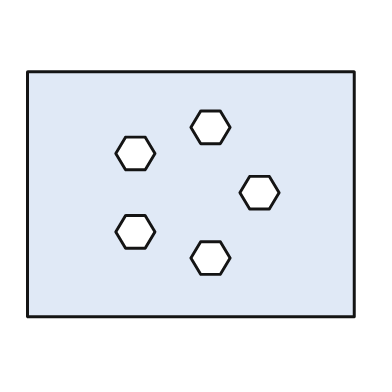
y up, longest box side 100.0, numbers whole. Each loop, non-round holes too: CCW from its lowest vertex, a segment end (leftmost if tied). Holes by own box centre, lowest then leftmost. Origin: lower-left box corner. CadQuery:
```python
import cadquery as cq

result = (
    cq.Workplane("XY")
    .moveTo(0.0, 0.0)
    .lineTo(100.0, 0.0)
    .lineTo(100.0, 75.0)
    .lineTo(0.0, 75.0)
    .close()
    .moveTo(53.0, 13.0)
    .lineTo(59.0, 13.0)
    .lineTo(62.0, 18.0)
    .lineTo(59.0, 23.0)
    .lineTo(53.0, 23.0)
    .lineTo(50.0, 18.0)
    .close()
    .moveTo(30.0, 21.0)
    .lineTo(36.0, 21.0)
    .lineTo(39.0, 26.0)
    .lineTo(36.0, 31.0)
    .lineTo(30.0, 31.0)
    .lineTo(27.0, 26.0)
    .close()
    .moveTo(68.0, 33.0)
    .lineTo(74.0, 33.0)
    .lineTo(77.0, 38.0)
    .lineTo(74.0, 43.0)
    .lineTo(68.0, 43.0)
    .lineTo(65.0, 38.0)
    .close()
    .moveTo(30.0, 45.0)
    .lineTo(36.0, 45.0)
    .lineTo(39.0, 50.0)
    .lineTo(36.0, 55.0)
    .lineTo(30.0, 55.0)
    .lineTo(27.0, 50.0)
    .close()
    .moveTo(53.0, 53.0)
    .lineTo(59.0, 53.0)
    .lineTo(62.0, 58.0)
    .lineTo(59.0, 63.0)
    .lineTo(53.0, 63.0)
    .lineTo(50.0, 58.0)
    .close()
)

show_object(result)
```